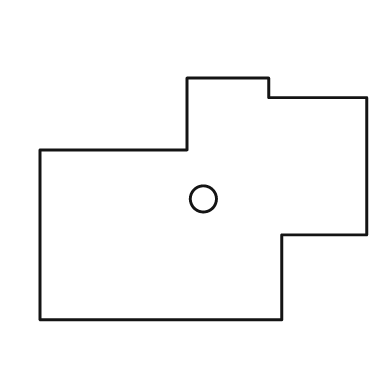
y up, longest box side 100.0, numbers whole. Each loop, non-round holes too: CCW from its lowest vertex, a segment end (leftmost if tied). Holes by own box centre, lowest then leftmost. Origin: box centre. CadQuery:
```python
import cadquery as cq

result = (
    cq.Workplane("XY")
    .moveTo(-50.0, -37.0)
    .lineTo(24.0, -37.0)
    .lineTo(24.0, -11.0)
    .lineTo(50.0, -11.0)
    .lineTo(50.0, 31.0)
    .lineTo(20.0, 31.0)
    .lineTo(20.0, 37.0)
    .lineTo(-5.0, 37.0)
    .lineTo(-5.0, 15.0)
    .lineTo(-50.0, 15.0)
    .close()
    .moveTo(0.0, 0.0)
    .circle(4.0)
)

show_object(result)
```